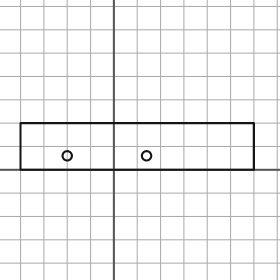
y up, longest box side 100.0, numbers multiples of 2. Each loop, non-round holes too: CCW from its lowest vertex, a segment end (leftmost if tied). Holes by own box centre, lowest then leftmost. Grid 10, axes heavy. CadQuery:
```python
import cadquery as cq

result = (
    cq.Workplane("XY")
    .moveTo(-40.0, 0.0)
    .lineTo(60.0, 0.0)
    .lineTo(60.0, 20.0)
    .lineTo(-40.0, 20.0)
    .close()
    .moveTo(-20.0, 6.0)
    .circle(2.0)
    .moveTo(14.0, 6.0)
    .circle(2.0)
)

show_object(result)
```